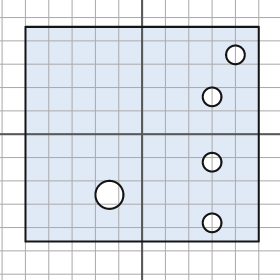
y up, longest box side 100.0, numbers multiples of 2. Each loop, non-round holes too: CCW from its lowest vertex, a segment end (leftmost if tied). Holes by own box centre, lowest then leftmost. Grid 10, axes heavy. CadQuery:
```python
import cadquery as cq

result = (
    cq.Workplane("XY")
    .moveTo(-50.0, -46.0)
    .lineTo(50.0, -46.0)
    .lineTo(50.0, 46.0)
    .lineTo(-50.0, 46.0)
    .close()
    .moveTo(30.0, -38.0)
    .circle(4.0)
    .moveTo(-14.0, -26.0)
    .circle(6.0)
    .moveTo(30.0, -12.0)
    .circle(4.0)
    .moveTo(30.0, 16.0)
    .circle(4.0)
    .moveTo(40.0, 34.0)
    .circle(4.0)
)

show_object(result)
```